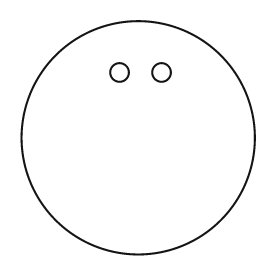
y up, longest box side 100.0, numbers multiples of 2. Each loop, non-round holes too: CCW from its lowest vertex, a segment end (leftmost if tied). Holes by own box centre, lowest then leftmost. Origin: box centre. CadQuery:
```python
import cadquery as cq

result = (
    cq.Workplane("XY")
    .moveTo(0.0, 0.0)
    .circle(50.0)
    .moveTo(-8.0, 28.0)
    .circle(4.0)
    .moveTo(10.0, 28.0)
    .circle(4.0)
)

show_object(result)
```